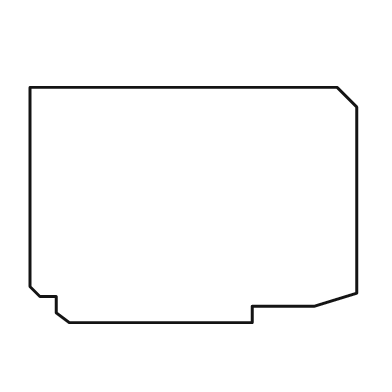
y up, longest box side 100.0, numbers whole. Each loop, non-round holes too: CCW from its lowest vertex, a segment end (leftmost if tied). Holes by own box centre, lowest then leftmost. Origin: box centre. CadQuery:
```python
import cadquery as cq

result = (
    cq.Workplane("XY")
    .moveTo(-38.0, -36.0)
    .lineTo(18.0, -36.0)
    .lineTo(18.0, -31.0)
    .lineTo(37.0, -31.0)
    .lineTo(50.0, -27.0)
    .lineTo(50.0, 30.0)
    .lineTo(44.0, 36.0)
    .lineTo(-50.0, 36.0)
    .lineTo(-50.0, -25.0)
    .lineTo(-47.0, -28.0)
    .lineTo(-42.0, -28.0)
    .lineTo(-42.0, -33.0)
    .close()
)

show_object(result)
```